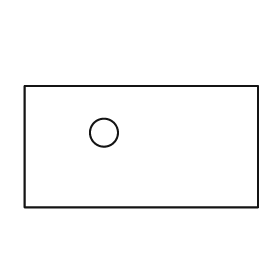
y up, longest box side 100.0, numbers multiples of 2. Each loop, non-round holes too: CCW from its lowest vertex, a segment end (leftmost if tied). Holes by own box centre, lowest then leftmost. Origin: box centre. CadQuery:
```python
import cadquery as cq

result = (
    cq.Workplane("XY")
    .moveTo(-50.0, -26.0)
    .lineTo(50.0, -26.0)
    .lineTo(50.0, 26.0)
    .lineTo(-50.0, 26.0)
    .close()
    .moveTo(-16.0, 6.0)
    .circle(6.0)
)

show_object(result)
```